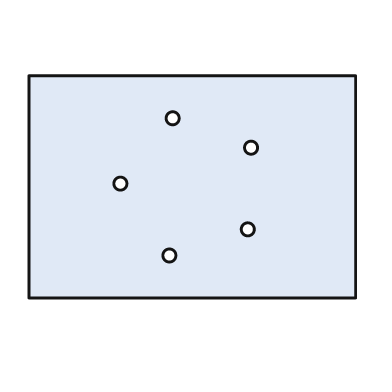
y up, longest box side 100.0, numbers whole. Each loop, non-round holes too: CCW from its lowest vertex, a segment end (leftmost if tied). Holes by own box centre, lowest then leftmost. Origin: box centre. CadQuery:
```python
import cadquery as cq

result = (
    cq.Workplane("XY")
    .moveTo(-50.0, -34.0)
    .lineTo(50.0, -34.0)
    .lineTo(50.0, 34.0)
    .lineTo(-50.0, 34.0)
    .close()
    .moveTo(-7.0, -21.0)
    .circle(2.0)
    .moveTo(17.0, -13.0)
    .circle(2.0)
    .moveTo(-22.0, 1.0)
    .circle(2.0)
    .moveTo(18.0, 12.0)
    .circle(2.0)
    .moveTo(-6.0, 21.0)
    .circle(2.0)
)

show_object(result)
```